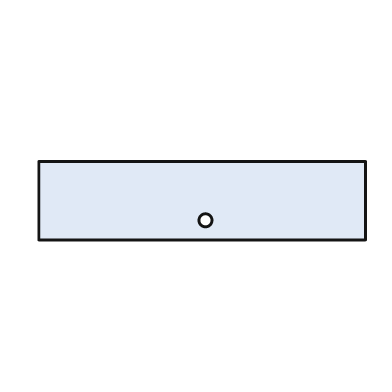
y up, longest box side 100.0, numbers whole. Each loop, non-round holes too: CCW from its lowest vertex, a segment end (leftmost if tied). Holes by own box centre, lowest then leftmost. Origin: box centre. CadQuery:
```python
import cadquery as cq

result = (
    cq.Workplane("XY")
    .moveTo(-50.0, -12.0)
    .lineTo(50.0, -12.0)
    .lineTo(50.0, 12.0)
    .lineTo(-50.0, 12.0)
    .close()
    .moveTo(1.0, -6.0)
    .circle(2.0)
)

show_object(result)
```